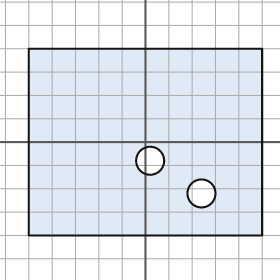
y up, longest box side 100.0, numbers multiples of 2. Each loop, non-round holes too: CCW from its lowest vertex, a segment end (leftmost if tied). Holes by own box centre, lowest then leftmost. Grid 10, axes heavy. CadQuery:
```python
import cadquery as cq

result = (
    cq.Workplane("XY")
    .moveTo(-50.0, -40.0)
    .lineTo(50.0, -40.0)
    .lineTo(50.0, 40.0)
    .lineTo(-50.0, 40.0)
    .close()
    .moveTo(24.0, -22.0)
    .circle(6.0)
    .moveTo(2.0, -8.0)
    .circle(6.0)
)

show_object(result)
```